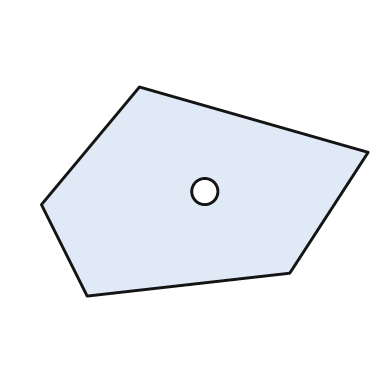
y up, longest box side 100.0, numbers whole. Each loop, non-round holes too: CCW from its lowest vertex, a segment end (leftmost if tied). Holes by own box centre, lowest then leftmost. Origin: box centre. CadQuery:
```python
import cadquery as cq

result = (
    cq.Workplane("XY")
    .moveTo(-36.0, -32.0)
    .lineTo(26.0, -25.0)
    .lineTo(50.0, 12.0)
    .lineTo(-20.0, 32.0)
    .lineTo(-50.0, -4.0)
    .close()
    .moveTo(0.0, 0.0)
    .circle(4.0)
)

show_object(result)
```